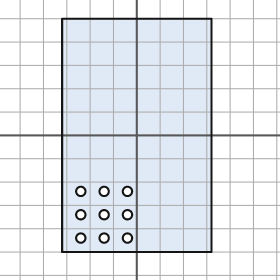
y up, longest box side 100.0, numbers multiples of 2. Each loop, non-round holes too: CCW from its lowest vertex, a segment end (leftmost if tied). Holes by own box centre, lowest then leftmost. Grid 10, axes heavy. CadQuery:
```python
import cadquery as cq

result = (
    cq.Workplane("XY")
    .moveTo(-32.0, -50.0)
    .lineTo(32.0, -50.0)
    .lineTo(32.0, 50.0)
    .lineTo(-32.0, 50.0)
    .close()
    .moveTo(-24.0, -44.0)
    .circle(2.0)
    .moveTo(-14.0, -44.0)
    .circle(2.0)
    .moveTo(-4.0, -44.0)
    .circle(2.0)
    .moveTo(-24.0, -34.0)
    .circle(2.0)
    .moveTo(-14.0, -34.0)
    .circle(2.0)
    .moveTo(-4.0, -34.0)
    .circle(2.0)
    .moveTo(-24.0, -24.0)
    .circle(2.0)
    .moveTo(-14.0, -24.0)
    .circle(2.0)
    .moveTo(-4.0, -24.0)
    .circle(2.0)
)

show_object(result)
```